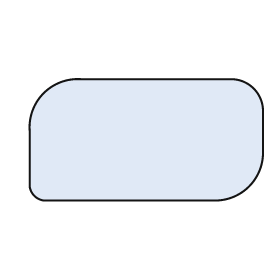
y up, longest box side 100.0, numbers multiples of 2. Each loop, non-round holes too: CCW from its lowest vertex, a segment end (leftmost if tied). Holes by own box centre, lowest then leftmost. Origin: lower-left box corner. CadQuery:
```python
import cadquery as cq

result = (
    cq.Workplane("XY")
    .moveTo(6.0, 0.0)
    .lineTo(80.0, 0.0)
    .threePointArc((94.0, 6.0), (100.0, 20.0))
    .lineTo(100.0, 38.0)
    .threePointArc((96.0, 48.0), (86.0, 52.0))
    .lineTo(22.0, 52.0)
    .threePointArc((6.0, 46.0), (0.0, 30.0))
    .lineTo(0.0, 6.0)
    .threePointArc((2.0, 2.0), (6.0, 0.0))
    .close()
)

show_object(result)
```